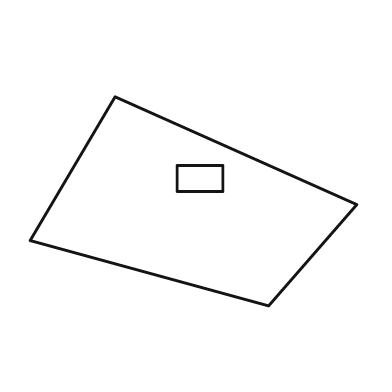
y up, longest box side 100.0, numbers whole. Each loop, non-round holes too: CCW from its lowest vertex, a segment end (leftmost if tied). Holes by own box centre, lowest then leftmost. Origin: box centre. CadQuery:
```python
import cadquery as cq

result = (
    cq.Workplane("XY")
    .moveTo(23.0, -32.0)
    .lineTo(50.0, -1.0)
    .lineTo(-24.0, 32.0)
    .lineTo(-50.0, -12.0)
    .close()
    .moveTo(-5.0, 3.0)
    .lineTo(9.0, 3.0)
    .lineTo(9.0, 11.0)
    .lineTo(-5.0, 11.0)
    .close()
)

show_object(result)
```